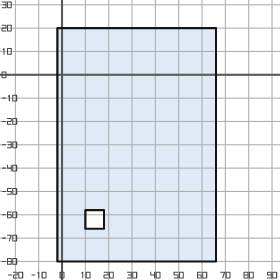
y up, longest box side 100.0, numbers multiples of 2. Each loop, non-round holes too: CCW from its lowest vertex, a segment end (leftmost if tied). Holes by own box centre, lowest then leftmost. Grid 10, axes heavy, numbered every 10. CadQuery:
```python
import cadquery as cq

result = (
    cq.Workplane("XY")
    .moveTo(-2.0, -80.0)
    .lineTo(66.0, -80.0)
    .lineTo(66.0, 20.0)
    .lineTo(-2.0, 20.0)
    .close()
    .moveTo(10.0, -66.0)
    .lineTo(18.0, -66.0)
    .lineTo(18.0, -58.0)
    .lineTo(10.0, -58.0)
    .close()
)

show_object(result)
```